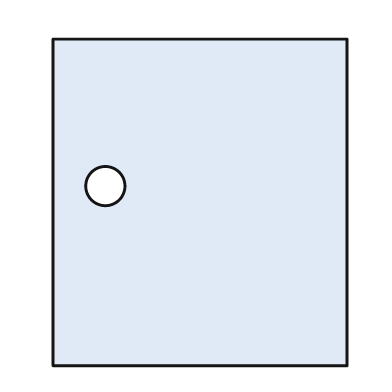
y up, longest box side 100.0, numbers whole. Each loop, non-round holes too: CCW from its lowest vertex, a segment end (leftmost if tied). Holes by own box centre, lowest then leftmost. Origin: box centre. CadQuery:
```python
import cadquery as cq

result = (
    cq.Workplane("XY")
    .moveTo(-45.0, -50.0)
    .lineTo(45.0, -50.0)
    .lineTo(45.0, 50.0)
    .lineTo(-45.0, 50.0)
    .close()
    .moveTo(-29.0, 5.0)
    .circle(6.0)
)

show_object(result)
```